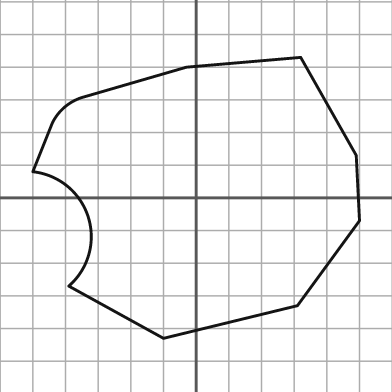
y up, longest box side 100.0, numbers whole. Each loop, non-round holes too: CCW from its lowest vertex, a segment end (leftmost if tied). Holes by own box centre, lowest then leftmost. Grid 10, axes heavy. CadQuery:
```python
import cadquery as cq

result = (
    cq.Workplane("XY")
    .moveTo(-10.0, -43.0)
    .lineTo(31.0, -33.0)
    .lineTo(50.0, -7.0)
    .lineTo(49.0, 13.0)
    .lineTo(32.0, 43.0)
    .lineTo(-3.0, 40.0)
    .lineTo(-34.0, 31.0)
    .threePointArc((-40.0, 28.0), (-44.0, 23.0))
    .lineTo(-50.0, 8.0)
    .threePointArc((-33.0, -6.0), (-39.0, -27.0))
    .close()
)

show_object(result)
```